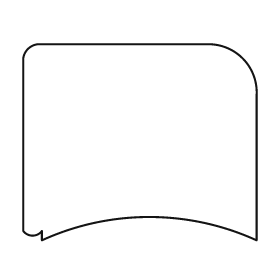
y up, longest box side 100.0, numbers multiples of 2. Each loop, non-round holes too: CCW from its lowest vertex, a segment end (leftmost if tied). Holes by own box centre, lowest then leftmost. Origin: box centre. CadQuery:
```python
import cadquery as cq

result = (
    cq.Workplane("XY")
    .moveTo(-42.0, -42.0)
    .threePointArc((4.0, -32.0), (50.0, -42.0))
    .lineTo(50.0, 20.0)
    .threePointArc((44.0, 36.0), (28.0, 42.0))
    .lineTo(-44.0, 42.0)
    .threePointArc((-48.0, 40.0), (-50.0, 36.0))
    .lineTo(-50.0, -38.0)
    .threePointArc((-46.0, -40.0), (-42.0, -38.0))
    .close()
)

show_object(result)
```